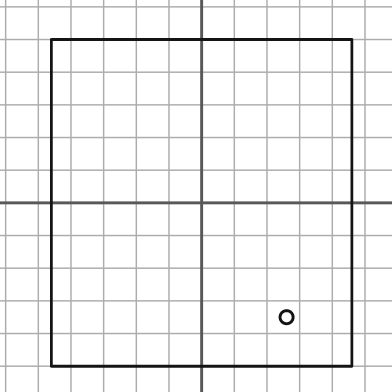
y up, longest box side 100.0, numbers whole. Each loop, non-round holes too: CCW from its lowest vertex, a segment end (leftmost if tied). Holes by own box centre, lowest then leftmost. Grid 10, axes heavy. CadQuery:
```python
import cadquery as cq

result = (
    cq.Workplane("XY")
    .moveTo(-46.0, -50.0)
    .lineTo(46.0, -50.0)
    .lineTo(46.0, 50.0)
    .lineTo(-46.0, 50.0)
    .close()
    .moveTo(26.0, -35.0)
    .circle(2.0)
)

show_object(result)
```